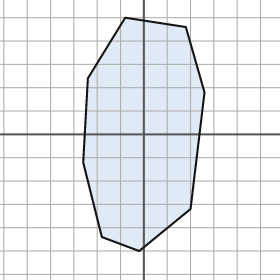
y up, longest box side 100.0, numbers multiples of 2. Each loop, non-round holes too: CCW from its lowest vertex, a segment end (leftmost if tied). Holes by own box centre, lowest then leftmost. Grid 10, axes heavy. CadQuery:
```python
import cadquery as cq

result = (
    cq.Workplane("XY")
    .moveTo(-2.0, -50.0)
    .lineTo(20.0, -32.0)
    .lineTo(26.0, 18.0)
    .lineTo(18.0, 46.0)
    .lineTo(-8.0, 50.0)
    .lineTo(-24.0, 24.0)
    .lineTo(-26.0, -12.0)
    .lineTo(-18.0, -44.0)
    .close()
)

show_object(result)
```